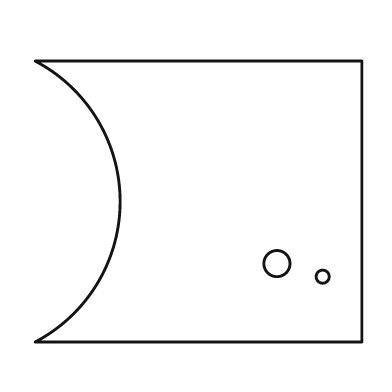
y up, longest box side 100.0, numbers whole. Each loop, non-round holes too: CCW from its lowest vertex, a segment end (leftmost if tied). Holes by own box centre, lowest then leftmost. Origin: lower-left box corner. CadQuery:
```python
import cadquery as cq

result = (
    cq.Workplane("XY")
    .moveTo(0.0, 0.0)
    .lineTo(100.0, 0.0)
    .lineTo(100.0, 86.0)
    .lineTo(0.0, 86.0)
    .threePointArc((26.0, 43.0), (0.0, 0.0))
    .close()
    .moveTo(88.0, 20.0)
    .circle(2.0)
    .moveTo(74.0, 24.0)
    .circle(4.0)
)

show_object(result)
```